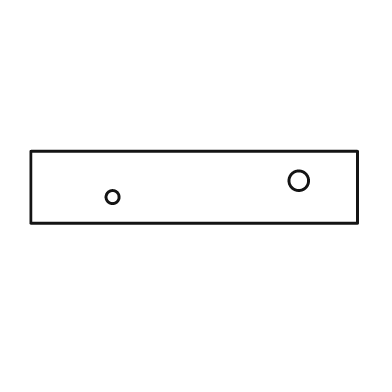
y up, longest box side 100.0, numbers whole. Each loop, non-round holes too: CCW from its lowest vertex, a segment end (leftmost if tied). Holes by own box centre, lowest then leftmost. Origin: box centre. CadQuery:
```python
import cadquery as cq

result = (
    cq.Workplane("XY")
    .moveTo(-50.0, -11.0)
    .lineTo(50.0, -11.0)
    .lineTo(50.0, 11.0)
    .lineTo(-50.0, 11.0)
    .close()
    .moveTo(-25.0, -3.0)
    .circle(2.0)
    .moveTo(32.0, 2.0)
    .circle(3.0)
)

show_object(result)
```